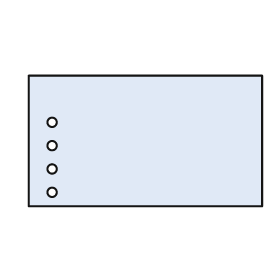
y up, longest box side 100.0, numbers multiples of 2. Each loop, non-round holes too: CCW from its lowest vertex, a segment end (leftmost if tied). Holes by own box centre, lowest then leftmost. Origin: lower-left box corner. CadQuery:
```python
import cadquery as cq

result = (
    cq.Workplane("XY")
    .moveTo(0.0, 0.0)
    .lineTo(100.0, 0.0)
    .lineTo(100.0, 56.0)
    .lineTo(0.0, 56.0)
    .close()
    .moveTo(10.0, 6.0)
    .circle(2.0)
    .moveTo(10.0, 16.0)
    .circle(2.0)
    .moveTo(10.0, 26.0)
    .circle(2.0)
    .moveTo(10.0, 36.0)
    .circle(2.0)
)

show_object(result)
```